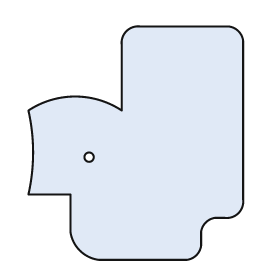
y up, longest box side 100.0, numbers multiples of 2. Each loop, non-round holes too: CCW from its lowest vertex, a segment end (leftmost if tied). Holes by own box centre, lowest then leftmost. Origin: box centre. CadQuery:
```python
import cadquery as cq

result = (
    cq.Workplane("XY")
    .moveTo(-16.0, -50.0)
    .lineTo(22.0, -50.0)
    .threePointArc((26.0, -48.0), (28.0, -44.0))
    .lineTo(28.0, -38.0)
    .threePointArc((30.0, -34.0), (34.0, -32.0))
    .lineTo(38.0, -32.0)
    .threePointArc((44.0, -30.0), (46.0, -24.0))
    .lineTo(46.0, 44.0)
    .threePointArc((44.0, 48.0), (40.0, 50.0))
    .lineTo(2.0, 50.0)
    .threePointArc((-4.0, 48.0), (-6.0, 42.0))
    .lineTo(-6.0, 14.0)
    .threePointArc((-26.0, 20.0), (-46.0, 14.0))
    .threePointArc((-44.0, -4.0), (-46.0, -22.0))
    .lineTo(-28.0, -22.0)
    .lineTo(-28.0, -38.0)
    .threePointArc((-24.0, -46.0), (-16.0, -50.0))
    .close()
    .moveTo(-20.0, -6.0)
    .circle(2.0)
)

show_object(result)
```